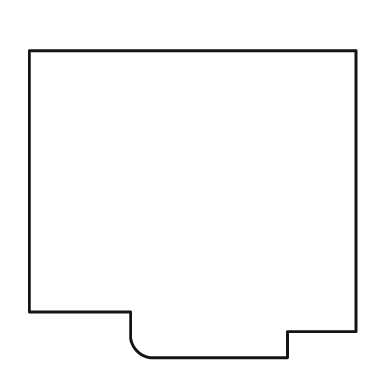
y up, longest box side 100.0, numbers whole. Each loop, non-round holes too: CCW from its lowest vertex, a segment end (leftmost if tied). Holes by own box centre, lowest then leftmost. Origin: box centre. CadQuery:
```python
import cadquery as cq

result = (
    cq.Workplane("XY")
    .moveTo(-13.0, -47.0)
    .lineTo(29.0, -47.0)
    .lineTo(29.0, -39.0)
    .lineTo(50.0, -39.0)
    .lineTo(50.0, 47.0)
    .lineTo(-50.0, 47.0)
    .lineTo(-50.0, -33.0)
    .lineTo(-19.0, -33.0)
    .lineTo(-19.0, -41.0)
    .threePointArc((-17.0, -45.0), (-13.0, -47.0))
    .close()
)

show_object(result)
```